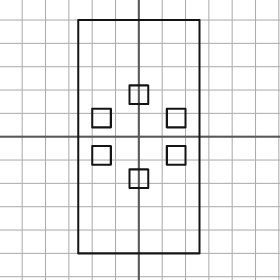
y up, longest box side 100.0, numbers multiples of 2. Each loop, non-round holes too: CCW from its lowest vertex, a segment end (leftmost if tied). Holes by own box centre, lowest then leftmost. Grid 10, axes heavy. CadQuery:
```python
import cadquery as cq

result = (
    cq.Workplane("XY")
    .moveTo(-26.0, -50.0)
    .lineTo(26.0, -50.0)
    .lineTo(26.0, 50.0)
    .lineTo(-26.0, 50.0)
    .close()
    .moveTo(-4.0, -22.0)
    .lineTo(4.0, -22.0)
    .lineTo(4.0, -14.0)
    .lineTo(-4.0, -14.0)
    .close()
    .moveTo(-20.0, -12.0)
    .lineTo(-12.0, -12.0)
    .lineTo(-12.0, -4.0)
    .lineTo(-20.0, -4.0)
    .close()
    .moveTo(12.0, -12.0)
    .lineTo(20.0, -12.0)
    .lineTo(20.0, -4.0)
    .lineTo(12.0, -4.0)
    .close()
    .moveTo(-20.0, 4.0)
    .lineTo(-12.0, 4.0)
    .lineTo(-12.0, 12.0)
    .lineTo(-20.0, 12.0)
    .close()
    .moveTo(12.0, 4.0)
    .lineTo(20.0, 4.0)
    .lineTo(20.0, 12.0)
    .lineTo(12.0, 12.0)
    .close()
    .moveTo(-4.0, 14.0)
    .lineTo(4.0, 14.0)
    .lineTo(4.0, 22.0)
    .lineTo(-4.0, 22.0)
    .close()
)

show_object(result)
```